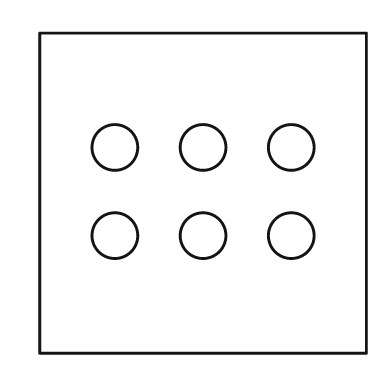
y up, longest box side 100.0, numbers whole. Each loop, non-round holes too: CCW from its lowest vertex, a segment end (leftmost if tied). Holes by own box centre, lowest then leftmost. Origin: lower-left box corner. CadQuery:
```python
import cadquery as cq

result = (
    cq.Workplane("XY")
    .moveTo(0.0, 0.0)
    .lineTo(100.0, 0.0)
    .lineTo(100.0, 98.0)
    .lineTo(0.0, 98.0)
    .close()
    .moveTo(23.0, 36.0)
    .circle(7.0)
    .moveTo(50.0, 36.0)
    .circle(7.0)
    .moveTo(77.0, 36.0)
    .circle(7.0)
    .moveTo(23.0, 63.0)
    .circle(7.0)
    .moveTo(50.0, 63.0)
    .circle(7.0)
    .moveTo(77.0, 63.0)
    .circle(7.0)
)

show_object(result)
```